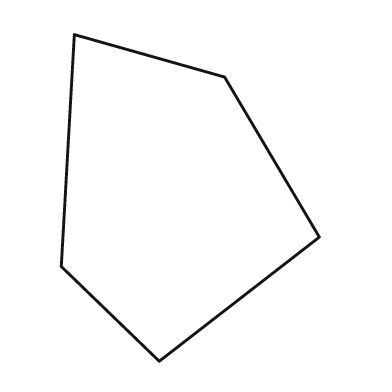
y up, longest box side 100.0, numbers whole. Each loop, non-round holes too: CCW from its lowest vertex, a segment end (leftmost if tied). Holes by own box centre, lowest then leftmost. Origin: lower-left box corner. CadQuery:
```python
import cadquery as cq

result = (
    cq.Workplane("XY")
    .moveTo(30.0, 0.0)
    .lineTo(79.0, 38.0)
    .lineTo(50.0, 87.0)
    .lineTo(4.0, 100.0)
    .lineTo(0.0, 29.0)
    .close()
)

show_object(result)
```